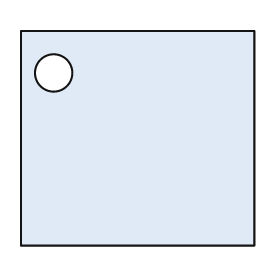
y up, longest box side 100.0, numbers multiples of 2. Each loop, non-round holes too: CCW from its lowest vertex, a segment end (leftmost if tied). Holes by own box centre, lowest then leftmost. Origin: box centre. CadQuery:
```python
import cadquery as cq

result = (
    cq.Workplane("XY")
    .moveTo(-50.0, -46.0)
    .lineTo(50.0, -46.0)
    .lineTo(50.0, 46.0)
    .lineTo(-50.0, 46.0)
    .close()
    .moveTo(-36.0, 28.0)
    .circle(8.0)
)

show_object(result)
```